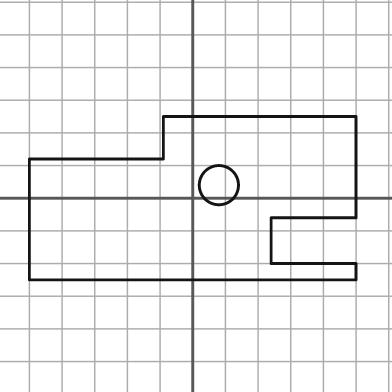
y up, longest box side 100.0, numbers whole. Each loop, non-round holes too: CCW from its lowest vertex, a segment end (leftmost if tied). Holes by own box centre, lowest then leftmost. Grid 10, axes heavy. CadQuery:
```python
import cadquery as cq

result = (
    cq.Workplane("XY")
    .moveTo(-50.0, -25.0)
    .lineTo(50.0, -25.0)
    .lineTo(50.0, -20.0)
    .lineTo(24.0, -20.0)
    .lineTo(24.0, -6.0)
    .lineTo(50.0, -6.0)
    .lineTo(50.0, 25.0)
    .lineTo(-9.0, 25.0)
    .lineTo(-9.0, 12.0)
    .lineTo(-50.0, 12.0)
    .close()
    .moveTo(8.0, 4.0)
    .circle(6.0)
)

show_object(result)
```